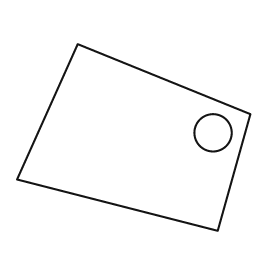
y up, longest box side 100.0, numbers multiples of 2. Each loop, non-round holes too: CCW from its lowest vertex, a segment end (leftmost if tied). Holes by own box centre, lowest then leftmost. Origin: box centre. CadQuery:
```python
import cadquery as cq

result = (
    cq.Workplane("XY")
    .moveTo(36.0, -40.0)
    .lineTo(50.0, 10.0)
    .lineTo(-24.0, 40.0)
    .lineTo(-50.0, -18.0)
    .close()
    .moveTo(34.0, 2.0)
    .circle(8.0)
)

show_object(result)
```